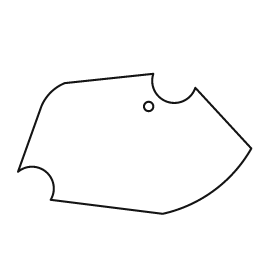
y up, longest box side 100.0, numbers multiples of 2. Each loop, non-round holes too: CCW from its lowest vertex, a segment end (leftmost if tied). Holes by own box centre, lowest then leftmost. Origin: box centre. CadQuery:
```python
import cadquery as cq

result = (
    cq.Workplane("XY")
    .moveTo(12.0, -30.0)
    .threePointArc((34.0, -20.0), (50.0, -2.0))
    .lineTo(26.0, 24.0)
    .threePointArc((14.0, 18.0), (8.0, 30.0))
    .lineTo(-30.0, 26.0)
    .threePointArc((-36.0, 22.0), (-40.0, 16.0))
    .lineTo(-50.0, -12.0)
    .threePointArc((-38.0, -12.0), (-36.0, -24.0))
    .close()
    .moveTo(6.0, 16.0)
    .circle(2.0)
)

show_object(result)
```